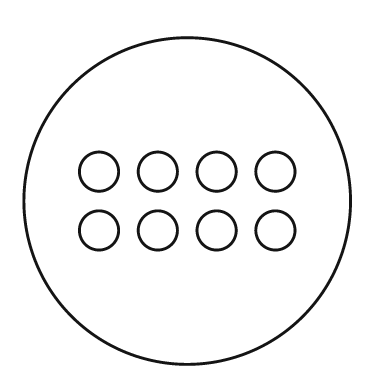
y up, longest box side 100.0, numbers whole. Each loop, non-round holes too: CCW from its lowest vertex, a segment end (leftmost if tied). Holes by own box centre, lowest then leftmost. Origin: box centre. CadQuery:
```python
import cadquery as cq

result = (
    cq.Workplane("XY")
    .moveTo(0.0, 0.0)
    .circle(50.0)
    .moveTo(-27.0, -9.0)
    .circle(6.0)
    .moveTo(-9.0, -9.0)
    .circle(6.0)
    .moveTo(9.0, -9.0)
    .circle(6.0)
    .moveTo(27.0, -9.0)
    .circle(6.0)
    .moveTo(-27.0, 9.0)
    .circle(6.0)
    .moveTo(-9.0, 9.0)
    .circle(6.0)
    .moveTo(9.0, 9.0)
    .circle(6.0)
    .moveTo(27.0, 9.0)
    .circle(6.0)
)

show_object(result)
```